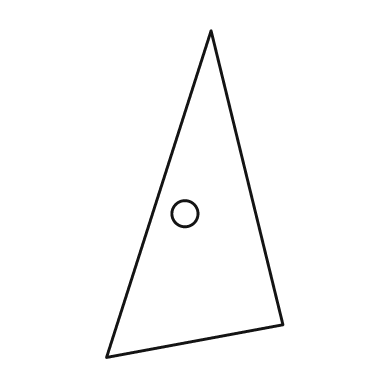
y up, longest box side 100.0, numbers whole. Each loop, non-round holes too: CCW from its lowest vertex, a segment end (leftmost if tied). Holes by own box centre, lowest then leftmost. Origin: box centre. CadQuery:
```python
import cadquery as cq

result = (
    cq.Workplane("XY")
    .moveTo(-27.0, -50.0)
    .lineTo(27.0, -40.0)
    .lineTo(5.0, 50.0)
    .close()
    .moveTo(-3.0, -6.0)
    .circle(4.0)
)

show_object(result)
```